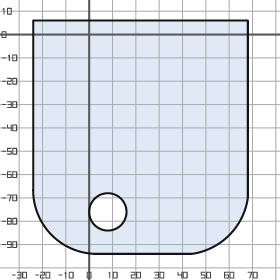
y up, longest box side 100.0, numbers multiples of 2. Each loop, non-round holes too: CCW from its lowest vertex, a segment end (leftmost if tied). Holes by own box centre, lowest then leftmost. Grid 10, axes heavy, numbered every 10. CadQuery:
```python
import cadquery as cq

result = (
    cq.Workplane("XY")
    .moveTo(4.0, -94.0)
    .lineTo(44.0, -94.0)
    .threePointArc((60.0, -86.0), (68.0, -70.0))
    .lineTo(68.0, 6.0)
    .lineTo(-24.0, 6.0)
    .lineTo(-24.0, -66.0)
    .threePointArc((-16.0, -86.0), (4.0, -94.0))
    .close()
    .moveTo(8.0, -76.0)
    .circle(8.0)
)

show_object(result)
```